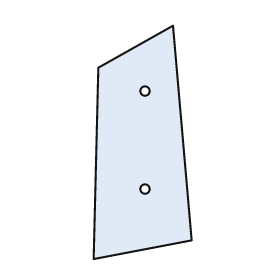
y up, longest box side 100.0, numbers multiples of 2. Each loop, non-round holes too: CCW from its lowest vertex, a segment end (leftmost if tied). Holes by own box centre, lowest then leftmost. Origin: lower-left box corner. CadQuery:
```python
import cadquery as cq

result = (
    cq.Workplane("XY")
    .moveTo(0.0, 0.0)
    .lineTo(42.0, 8.0)
    .lineTo(34.0, 100.0)
    .lineTo(2.0, 82.0)
    .close()
    .moveTo(22.0, 30.0)
    .circle(2.0)
    .moveTo(22.0, 72.0)
    .circle(2.0)
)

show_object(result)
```